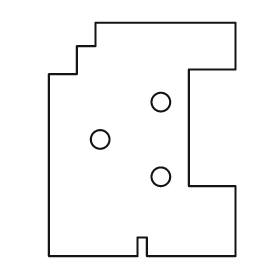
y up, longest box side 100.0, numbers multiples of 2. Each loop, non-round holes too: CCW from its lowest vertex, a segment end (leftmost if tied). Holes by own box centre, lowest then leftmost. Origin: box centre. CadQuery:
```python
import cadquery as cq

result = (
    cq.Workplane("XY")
    .moveTo(-40.0, -50.0)
    .lineTo(-2.0, -50.0)
    .lineTo(-2.0, -42.0)
    .lineTo(2.0, -42.0)
    .lineTo(2.0, -50.0)
    .lineTo(40.0, -50.0)
    .lineTo(40.0, -20.0)
    .lineTo(20.0, -20.0)
    .lineTo(20.0, 30.0)
    .lineTo(40.0, 30.0)
    .lineTo(40.0, 50.0)
    .lineTo(-20.0, 50.0)
    .lineTo(-20.0, 40.0)
    .lineTo(-28.0, 40.0)
    .lineTo(-28.0, 28.0)
    .lineTo(-40.0, 28.0)
    .close()
    .moveTo(8.0, -16.0)
    .circle(4.0)
    .moveTo(-18.0, 0.0)
    .circle(4.0)
    .moveTo(8.0, 16.0)
    .circle(4.0)
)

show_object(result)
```